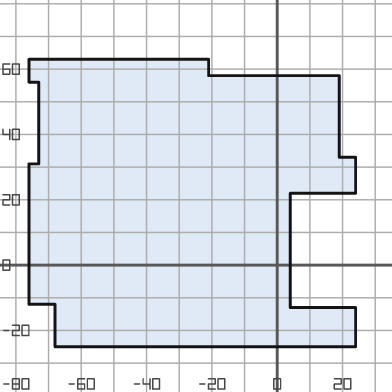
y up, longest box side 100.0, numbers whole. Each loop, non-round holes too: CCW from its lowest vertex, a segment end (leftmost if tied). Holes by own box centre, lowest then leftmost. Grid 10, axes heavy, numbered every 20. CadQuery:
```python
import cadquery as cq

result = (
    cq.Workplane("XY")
    .moveTo(-68.0, -25.0)
    .lineTo(24.0, -25.0)
    .lineTo(24.0, -13.0)
    .lineTo(4.0, -13.0)
    .lineTo(4.0, 22.0)
    .lineTo(24.0, 22.0)
    .lineTo(24.0, 33.0)
    .lineTo(19.0, 33.0)
    .lineTo(19.0, 58.0)
    .lineTo(-21.0, 58.0)
    .lineTo(-21.0, 63.0)
    .lineTo(-76.0, 63.0)
    .lineTo(-76.0, 56.0)
    .lineTo(-73.0, 56.0)
    .lineTo(-73.0, 31.0)
    .lineTo(-76.0, 31.0)
    .lineTo(-76.0, -12.0)
    .lineTo(-68.0, -12.0)
    .close()
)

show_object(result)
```